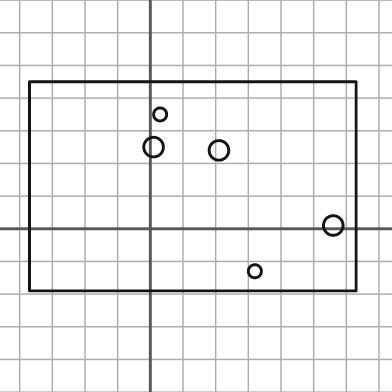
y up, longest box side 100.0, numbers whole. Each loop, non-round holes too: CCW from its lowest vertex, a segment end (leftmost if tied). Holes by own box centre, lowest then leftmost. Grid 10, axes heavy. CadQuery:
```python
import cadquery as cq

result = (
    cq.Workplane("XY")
    .moveTo(-37.0, -19.0)
    .lineTo(63.0, -19.0)
    .lineTo(63.0, 45.0)
    .lineTo(-37.0, 45.0)
    .close()
    .moveTo(32.0, -13.0)
    .circle(2.0)
    .moveTo(56.0, 1.0)
    .circle(3.0)
    .moveTo(21.0, 24.0)
    .circle(3.0)
    .moveTo(1.0, 25.0)
    .circle(3.0)
    .moveTo(3.0, 35.0)
    .circle(2.0)
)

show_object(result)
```